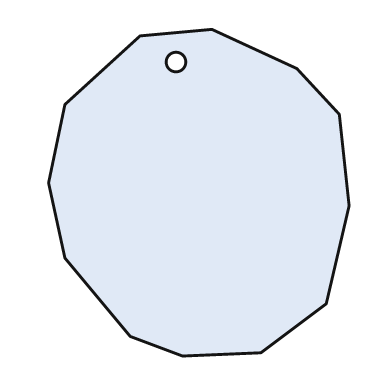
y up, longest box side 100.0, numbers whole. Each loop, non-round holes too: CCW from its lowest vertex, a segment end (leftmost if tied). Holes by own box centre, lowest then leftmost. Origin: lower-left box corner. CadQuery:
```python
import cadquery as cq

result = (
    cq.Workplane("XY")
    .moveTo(41.0, 0.0)
    .lineTo(65.0, 1.0)
    .lineTo(85.0, 16.0)
    .lineTo(92.0, 46.0)
    .lineTo(89.0, 74.0)
    .lineTo(76.0, 88.0)
    .lineTo(50.0, 100.0)
    .lineTo(28.0, 98.0)
    .lineTo(5.0, 77.0)
    .lineTo(0.0, 53.0)
    .lineTo(5.0, 30.0)
    .lineTo(25.0, 6.0)
    .close()
    .moveTo(39.0, 90.0)
    .circle(3.0)
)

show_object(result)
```